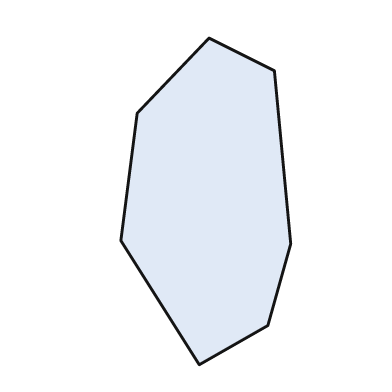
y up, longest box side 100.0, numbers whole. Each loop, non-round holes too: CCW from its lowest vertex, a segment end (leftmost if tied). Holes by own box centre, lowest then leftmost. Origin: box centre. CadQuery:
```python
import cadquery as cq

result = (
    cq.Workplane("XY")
    .moveTo(-2.0, -50.0)
    .lineTo(19.0, -38.0)
    .lineTo(26.0, -13.0)
    .lineTo(21.0, 40.0)
    .lineTo(1.0, 50.0)
    .lineTo(-21.0, 27.0)
    .lineTo(-26.0, -12.0)
    .close()
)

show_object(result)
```